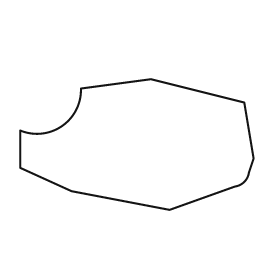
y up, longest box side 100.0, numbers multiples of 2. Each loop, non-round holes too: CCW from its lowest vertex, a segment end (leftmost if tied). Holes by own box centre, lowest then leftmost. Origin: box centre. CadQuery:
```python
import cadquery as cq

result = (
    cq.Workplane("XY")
    .moveTo(14.0, -28.0)
    .lineTo(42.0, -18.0)
    .threePointArc((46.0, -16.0), (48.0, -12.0))
    .lineTo(50.0, -6.0)
    .lineTo(46.0, 18.0)
    .lineTo(6.0, 28.0)
    .lineTo(-24.0, 24.0)
    .threePointArc((-32.0, 8.0), (-50.0, 6.0))
    .lineTo(-50.0, -10.0)
    .lineTo(-28.0, -20.0)
    .close()
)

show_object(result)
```